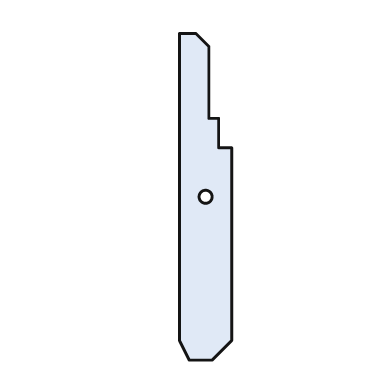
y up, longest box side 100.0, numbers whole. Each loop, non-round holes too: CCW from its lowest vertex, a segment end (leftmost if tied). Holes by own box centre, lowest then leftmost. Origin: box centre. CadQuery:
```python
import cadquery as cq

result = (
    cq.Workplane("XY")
    .moveTo(-5.0, -50.0)
    .lineTo(2.0, -50.0)
    .lineTo(8.0, -44.0)
    .lineTo(8.0, 15.0)
    .lineTo(4.0, 15.0)
    .lineTo(4.0, 24.0)
    .lineTo(1.0, 24.0)
    .lineTo(1.0, 46.0)
    .lineTo(-3.0, 50.0)
    .lineTo(-8.0, 50.0)
    .lineTo(-8.0, -44.0)
    .close()
    .moveTo(0.0, 0.0)
    .circle(2.0)
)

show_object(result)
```